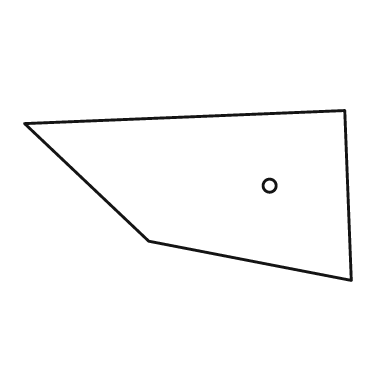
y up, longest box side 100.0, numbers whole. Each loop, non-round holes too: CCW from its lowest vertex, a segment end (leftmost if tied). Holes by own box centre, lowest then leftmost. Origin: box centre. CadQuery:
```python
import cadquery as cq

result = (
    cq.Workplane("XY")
    .moveTo(50.0, -26.0)
    .lineTo(48.0, 26.0)
    .lineTo(-50.0, 22.0)
    .lineTo(-12.0, -14.0)
    .close()
    .moveTo(25.0, 3.0)
    .circle(2.0)
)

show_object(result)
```